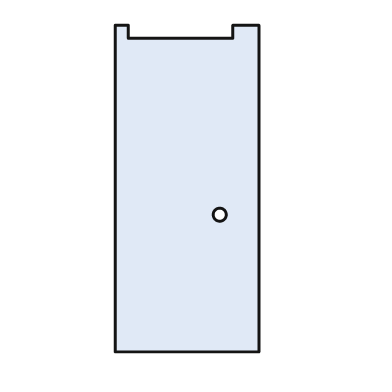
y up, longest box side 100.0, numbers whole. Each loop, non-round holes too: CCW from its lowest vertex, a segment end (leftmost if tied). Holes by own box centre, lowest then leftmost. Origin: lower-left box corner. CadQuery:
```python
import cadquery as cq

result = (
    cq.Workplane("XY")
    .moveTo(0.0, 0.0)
    .lineTo(44.0, 0.0)
    .lineTo(44.0, 100.0)
    .lineTo(36.0, 100.0)
    .lineTo(36.0, 96.0)
    .lineTo(4.0, 96.0)
    .lineTo(4.0, 100.0)
    .lineTo(0.0, 100.0)
    .close()
    .moveTo(32.0, 42.0)
    .circle(2.0)
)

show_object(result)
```